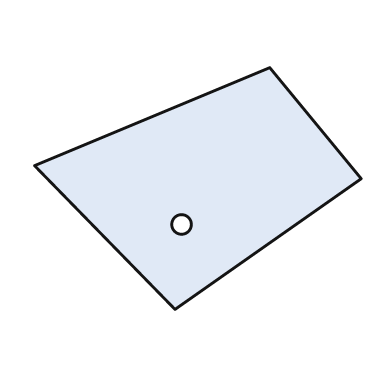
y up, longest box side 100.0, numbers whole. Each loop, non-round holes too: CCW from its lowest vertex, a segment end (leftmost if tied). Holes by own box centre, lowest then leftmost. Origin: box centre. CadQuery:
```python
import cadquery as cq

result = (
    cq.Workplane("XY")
    .moveTo(-7.0, -37.0)
    .lineTo(50.0, 3.0)
    .lineTo(22.0, 37.0)
    .lineTo(-50.0, 7.0)
    .close()
    .moveTo(-5.0, -11.0)
    .circle(3.0)
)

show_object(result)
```